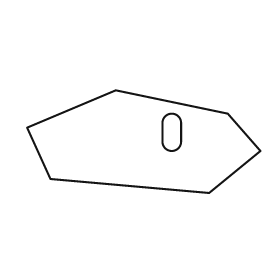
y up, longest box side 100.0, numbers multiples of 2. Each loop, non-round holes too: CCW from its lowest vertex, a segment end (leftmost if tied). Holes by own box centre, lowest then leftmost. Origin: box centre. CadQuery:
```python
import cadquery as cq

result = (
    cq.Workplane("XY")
    .moveTo(28.0, -22.0)
    .lineTo(50.0, -4.0)
    .lineTo(36.0, 12.0)
    .lineTo(-12.0, 22.0)
    .lineTo(-50.0, 6.0)
    .lineTo(-40.0, -16.0)
    .close()
    .moveTo(8.0, 0.0)
    .threePointArc((12.0, -4.0), (16.0, 0.0))
    .lineTo(16.0, 8.0)
    .threePointArc((12.0, 12.0), (8.0, 8.0))
    .close()
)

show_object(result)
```